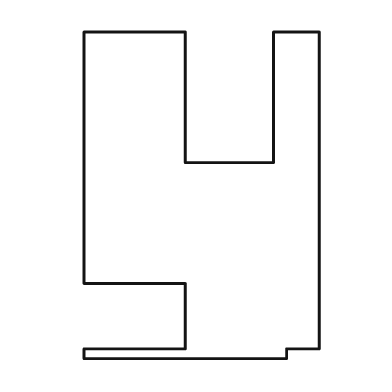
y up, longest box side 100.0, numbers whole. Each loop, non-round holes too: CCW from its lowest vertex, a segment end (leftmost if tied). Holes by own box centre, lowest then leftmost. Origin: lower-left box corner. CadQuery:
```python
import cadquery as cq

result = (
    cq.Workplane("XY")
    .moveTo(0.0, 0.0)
    .lineTo(62.0, 0.0)
    .lineTo(62.0, 3.0)
    .lineTo(72.0, 3.0)
    .lineTo(72.0, 100.0)
    .lineTo(58.0, 100.0)
    .lineTo(58.0, 60.0)
    .lineTo(31.0, 60.0)
    .lineTo(31.0, 100.0)
    .lineTo(0.0, 100.0)
    .lineTo(0.0, 23.0)
    .lineTo(31.0, 23.0)
    .lineTo(31.0, 3.0)
    .lineTo(0.0, 3.0)
    .close()
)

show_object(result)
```